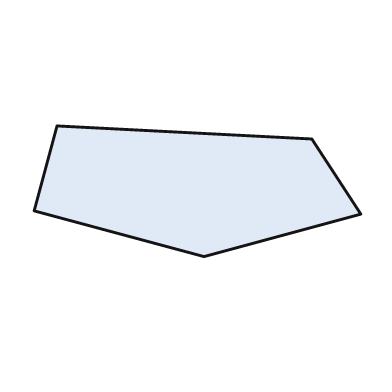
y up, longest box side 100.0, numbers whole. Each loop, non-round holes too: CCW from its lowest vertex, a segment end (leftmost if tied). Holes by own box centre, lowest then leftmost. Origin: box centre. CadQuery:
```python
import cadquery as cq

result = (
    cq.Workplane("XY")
    .moveTo(2.0, -20.0)
    .lineTo(50.0, -7.0)
    .lineTo(35.0, 16.0)
    .lineTo(-43.0, 20.0)
    .lineTo(-50.0, -6.0)
    .close()
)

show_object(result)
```